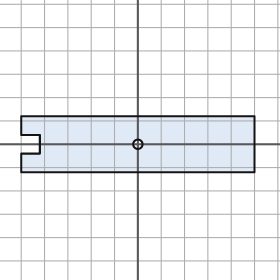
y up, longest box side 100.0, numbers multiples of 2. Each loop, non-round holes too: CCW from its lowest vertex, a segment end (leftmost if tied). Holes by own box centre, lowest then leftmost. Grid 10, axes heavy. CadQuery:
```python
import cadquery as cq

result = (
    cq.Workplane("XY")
    .moveTo(-50.0, -12.0)
    .lineTo(50.0, -12.0)
    .lineTo(50.0, 12.0)
    .lineTo(-50.0, 12.0)
    .lineTo(-50.0, 4.0)
    .lineTo(-42.0, 4.0)
    .lineTo(-42.0, -4.0)
    .lineTo(-50.0, -4.0)
    .close()
    .moveTo(0.0, 0.0)
    .circle(2.0)
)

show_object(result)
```